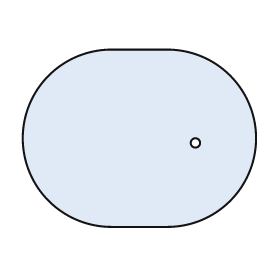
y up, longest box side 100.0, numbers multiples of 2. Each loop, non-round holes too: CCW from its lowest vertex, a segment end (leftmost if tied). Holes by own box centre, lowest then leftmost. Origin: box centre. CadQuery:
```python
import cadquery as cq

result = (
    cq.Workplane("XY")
    .moveTo(-12.0, -38.0)
    .lineTo(12.0, -38.0)
    .threePointArc((50.0, 0.0), (12.0, 38.0))
    .lineTo(-12.0, 38.0)
    .threePointArc((-50.0, 0.0), (-12.0, -38.0))
    .close()
    .moveTo(24.0, -2.0)
    .circle(2.0)
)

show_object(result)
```